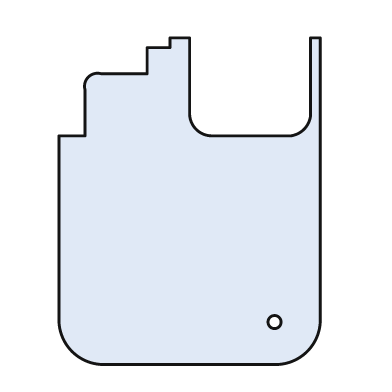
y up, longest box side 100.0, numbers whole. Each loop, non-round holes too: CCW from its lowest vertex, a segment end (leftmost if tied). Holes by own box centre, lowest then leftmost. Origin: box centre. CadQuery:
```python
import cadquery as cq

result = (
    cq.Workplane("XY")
    .moveTo(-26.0, -50.0)
    .lineTo(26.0, -50.0)
    .threePointArc((36.0, -46.0), (40.0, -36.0))
    .lineTo(40.0, 50.0)
    .lineTo(37.0, 50.0)
    .lineTo(37.0, 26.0)
    .threePointArc((35.0, 22.0), (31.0, 20.0))
    .lineTo(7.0, 20.0)
    .threePointArc((2.0, 22.0), (0.0, 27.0))
    .lineTo(0.0, 50.0)
    .lineTo(-6.0, 50.0)
    .lineTo(-6.0, 47.0)
    .lineTo(-13.0, 47.0)
    .lineTo(-13.0, 39.0)
    .lineTo(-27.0, 39.0)
    .threePointArc((-31.0, 38.0), (-32.0, 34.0))
    .lineTo(-32.0, 20.0)
    .lineTo(-40.0, 20.0)
    .lineTo(-40.0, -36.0)
    .threePointArc((-36.0, -46.0), (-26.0, -50.0))
    .close()
    .moveTo(26.0, -37.0)
    .circle(2.0)
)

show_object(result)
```